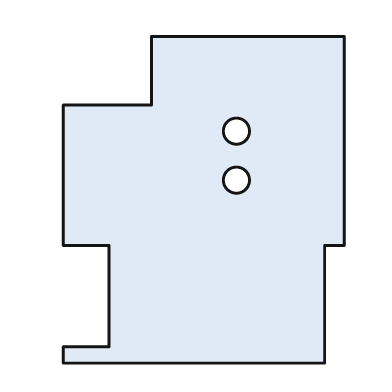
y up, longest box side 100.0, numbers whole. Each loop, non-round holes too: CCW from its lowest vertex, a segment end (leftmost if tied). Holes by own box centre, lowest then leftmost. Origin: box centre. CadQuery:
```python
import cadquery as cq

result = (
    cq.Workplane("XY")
    .moveTo(-43.0, -50.0)
    .lineTo(37.0, -50.0)
    .lineTo(37.0, -14.0)
    .lineTo(43.0, -14.0)
    .lineTo(43.0, 50.0)
    .lineTo(-16.0, 50.0)
    .lineTo(-16.0, 29.0)
    .lineTo(-43.0, 29.0)
    .lineTo(-43.0, -14.0)
    .lineTo(-29.0, -14.0)
    .lineTo(-29.0, -45.0)
    .lineTo(-43.0, -45.0)
    .close()
    .moveTo(10.0, 6.0)
    .circle(4.0)
    .moveTo(10.0, 21.0)
    .circle(4.0)
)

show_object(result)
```